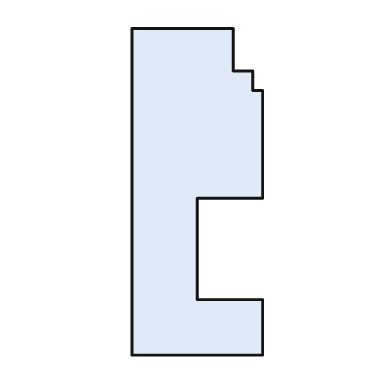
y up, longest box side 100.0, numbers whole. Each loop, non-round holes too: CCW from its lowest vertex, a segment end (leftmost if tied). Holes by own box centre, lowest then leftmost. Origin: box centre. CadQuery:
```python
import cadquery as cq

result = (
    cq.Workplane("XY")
    .moveTo(-20.0, -50.0)
    .lineTo(20.0, -50.0)
    .lineTo(20.0, -33.0)
    .lineTo(0.0, -33.0)
    .lineTo(0.0, -2.0)
    .lineTo(20.0, -2.0)
    .lineTo(20.0, 31.0)
    .lineTo(17.0, 31.0)
    .lineTo(17.0, 37.0)
    .lineTo(11.0, 37.0)
    .lineTo(11.0, 50.0)
    .lineTo(-20.0, 50.0)
    .close()
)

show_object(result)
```